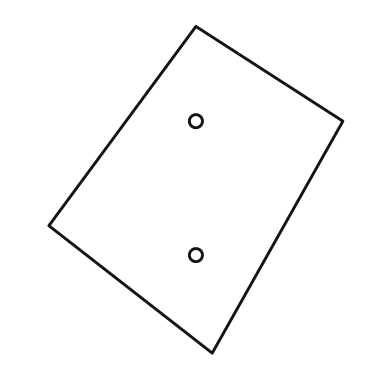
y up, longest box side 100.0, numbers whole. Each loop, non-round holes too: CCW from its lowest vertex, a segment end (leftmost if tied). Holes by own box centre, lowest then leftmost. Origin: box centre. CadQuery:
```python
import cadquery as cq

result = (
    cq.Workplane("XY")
    .moveTo(5.0, -50.0)
    .lineTo(45.0, 21.0)
    .lineTo(0.0, 50.0)
    .lineTo(-45.0, -11.0)
    .close()
    .moveTo(0.0, -20.0)
    .circle(2.0)
    .moveTo(0.0, 21.0)
    .circle(2.0)
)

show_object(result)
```